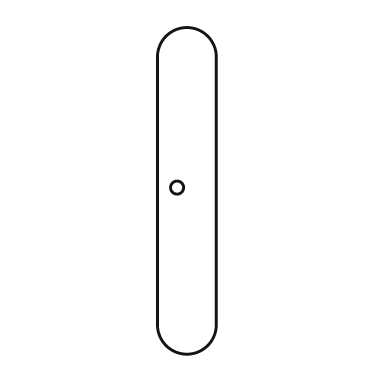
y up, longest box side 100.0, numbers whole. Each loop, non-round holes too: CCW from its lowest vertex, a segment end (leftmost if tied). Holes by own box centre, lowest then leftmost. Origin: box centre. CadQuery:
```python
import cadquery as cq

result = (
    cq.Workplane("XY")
    .moveTo(-9.0, -41.0)
    .threePointArc((0.0, -50.0), (9.0, -41.0))
    .lineTo(9.0, 41.0)
    .threePointArc((0.0, 50.0), (-9.0, 41.0))
    .close()
    .moveTo(-3.0, 1.0)
    .circle(2.0)
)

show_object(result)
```